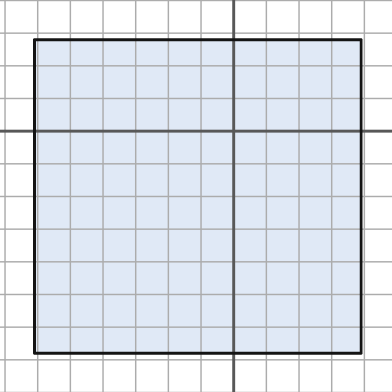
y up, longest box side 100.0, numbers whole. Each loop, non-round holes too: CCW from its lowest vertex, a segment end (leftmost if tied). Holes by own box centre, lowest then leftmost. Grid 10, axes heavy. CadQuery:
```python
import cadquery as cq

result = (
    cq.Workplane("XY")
    .moveTo(-61.0, -68.0)
    .lineTo(39.0, -68.0)
    .lineTo(39.0, 28.0)
    .lineTo(-61.0, 28.0)
    .close()
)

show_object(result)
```